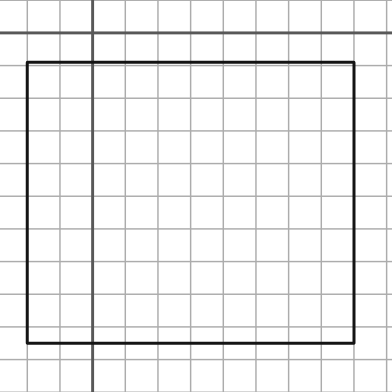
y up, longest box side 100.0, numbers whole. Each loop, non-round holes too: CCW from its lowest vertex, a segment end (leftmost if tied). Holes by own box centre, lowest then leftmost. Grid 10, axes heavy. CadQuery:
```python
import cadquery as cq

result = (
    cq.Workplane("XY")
    .moveTo(-20.0, -95.0)
    .lineTo(80.0, -95.0)
    .lineTo(80.0, -9.0)
    .lineTo(-20.0, -9.0)
    .close()
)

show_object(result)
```